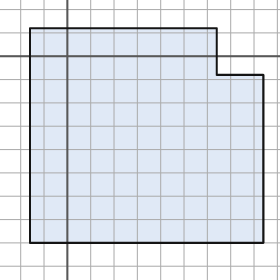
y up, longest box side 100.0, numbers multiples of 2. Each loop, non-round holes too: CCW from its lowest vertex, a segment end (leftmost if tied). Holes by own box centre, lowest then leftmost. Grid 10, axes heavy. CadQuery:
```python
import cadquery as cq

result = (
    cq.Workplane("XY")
    .moveTo(-16.0, -80.0)
    .lineTo(84.0, -80.0)
    .lineTo(84.0, -8.0)
    .lineTo(64.0, -8.0)
    .lineTo(64.0, 12.0)
    .lineTo(-16.0, 12.0)
    .close()
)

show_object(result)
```